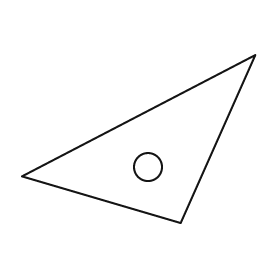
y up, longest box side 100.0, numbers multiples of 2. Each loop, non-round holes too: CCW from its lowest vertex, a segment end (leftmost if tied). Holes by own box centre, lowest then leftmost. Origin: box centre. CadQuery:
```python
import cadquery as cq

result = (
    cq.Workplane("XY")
    .moveTo(18.0, -36.0)
    .lineTo(50.0, 36.0)
    .lineTo(-50.0, -16.0)
    .close()
    .moveTo(4.0, -12.0)
    .circle(6.0)
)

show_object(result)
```